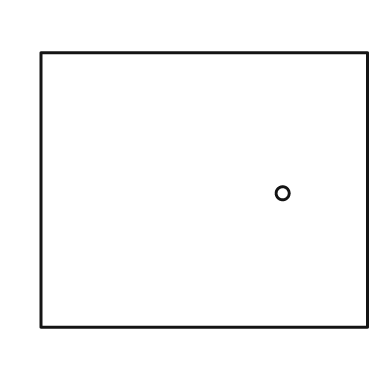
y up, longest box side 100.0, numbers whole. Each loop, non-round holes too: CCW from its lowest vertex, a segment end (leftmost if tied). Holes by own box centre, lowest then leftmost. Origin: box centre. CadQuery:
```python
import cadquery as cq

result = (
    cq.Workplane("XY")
    .moveTo(-50.0, -42.0)
    .lineTo(50.0, -42.0)
    .lineTo(50.0, 42.0)
    .lineTo(-50.0, 42.0)
    .close()
    .moveTo(24.0, -1.0)
    .circle(2.0)
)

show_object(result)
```